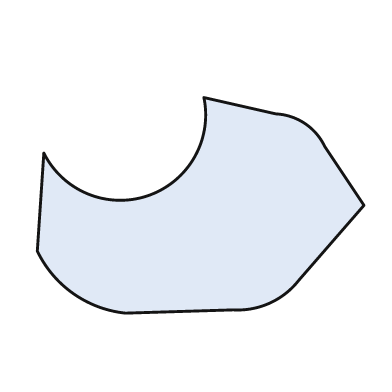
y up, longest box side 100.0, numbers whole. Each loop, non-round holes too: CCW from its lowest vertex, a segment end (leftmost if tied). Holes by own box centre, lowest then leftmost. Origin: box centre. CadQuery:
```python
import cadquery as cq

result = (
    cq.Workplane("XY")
    .moveTo(-23.0, -33.0)
    .lineTo(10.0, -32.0)
    .threePointArc((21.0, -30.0), (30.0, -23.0))
    .lineTo(50.0, 0.0)
    .lineTo(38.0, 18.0)
    .threePointArc((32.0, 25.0), (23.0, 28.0))
    .lineTo(1.0, 33.0)
    .threePointArc((-16.0, 3.0), (-48.0, 16.0))
    .lineTo(-50.0, -14.0)
    .threePointArc((-39.0, -27.0), (-23.0, -33.0))
    .close()
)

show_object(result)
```